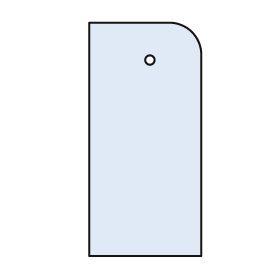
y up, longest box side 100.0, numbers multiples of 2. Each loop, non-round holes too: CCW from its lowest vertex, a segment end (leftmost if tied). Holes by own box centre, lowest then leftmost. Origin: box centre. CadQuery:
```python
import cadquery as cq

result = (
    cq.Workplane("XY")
    .moveTo(-24.0, -50.0)
    .lineTo(24.0, -50.0)
    .lineTo(24.0, 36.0)
    .threePointArc((20.0, 46.0), (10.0, 50.0))
    .lineTo(-24.0, 50.0)
    .close()
    .moveTo(2.0, 34.0)
    .circle(2.0)
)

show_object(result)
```